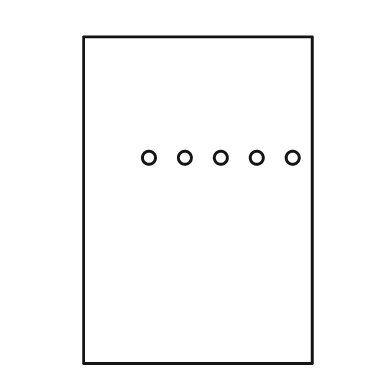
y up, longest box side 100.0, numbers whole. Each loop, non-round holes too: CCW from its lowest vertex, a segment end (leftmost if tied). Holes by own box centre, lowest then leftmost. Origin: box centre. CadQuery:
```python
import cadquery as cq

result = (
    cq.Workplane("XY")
    .moveTo(-35.0, -50.0)
    .lineTo(35.0, -50.0)
    .lineTo(35.0, 50.0)
    .lineTo(-35.0, 50.0)
    .close()
    .moveTo(-15.0, 13.0)
    .circle(2.0)
    .moveTo(-4.0, 13.0)
    .circle(2.0)
    .moveTo(7.0, 13.0)
    .circle(2.0)
    .moveTo(18.0, 13.0)
    .circle(2.0)
    .moveTo(29.0, 13.0)
    .circle(2.0)
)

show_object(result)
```